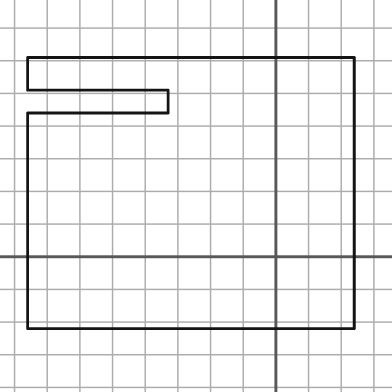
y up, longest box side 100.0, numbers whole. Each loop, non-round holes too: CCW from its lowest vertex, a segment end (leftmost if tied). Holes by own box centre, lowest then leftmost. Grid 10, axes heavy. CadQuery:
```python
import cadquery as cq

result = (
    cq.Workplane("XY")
    .moveTo(-76.0, -22.0)
    .lineTo(24.0, -22.0)
    .lineTo(24.0, 61.0)
    .lineTo(-76.0, 61.0)
    .lineTo(-76.0, 51.0)
    .lineTo(-33.0, 51.0)
    .lineTo(-33.0, 44.0)
    .lineTo(-76.0, 44.0)
    .close()
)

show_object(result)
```